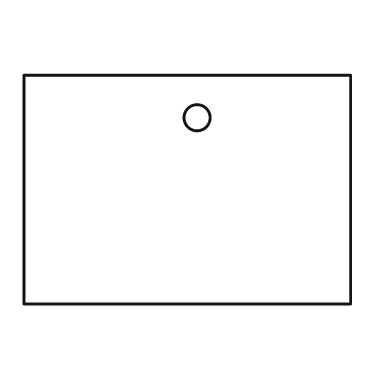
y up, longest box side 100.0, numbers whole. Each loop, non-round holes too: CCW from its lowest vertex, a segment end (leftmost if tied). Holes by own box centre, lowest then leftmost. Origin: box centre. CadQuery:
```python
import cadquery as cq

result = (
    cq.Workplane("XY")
    .moveTo(-50.0, -35.0)
    .lineTo(50.0, -35.0)
    .lineTo(50.0, 35.0)
    .lineTo(-50.0, 35.0)
    .close()
    .moveTo(3.0, 22.0)
    .circle(4.0)
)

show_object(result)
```